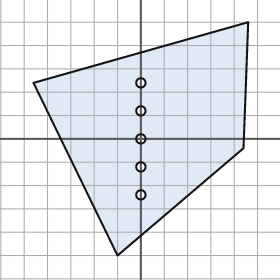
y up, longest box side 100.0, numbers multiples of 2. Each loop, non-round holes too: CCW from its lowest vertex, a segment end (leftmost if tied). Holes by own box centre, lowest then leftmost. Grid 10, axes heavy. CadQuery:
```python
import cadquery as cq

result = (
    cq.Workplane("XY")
    .moveTo(-10.0, -50.0)
    .lineTo(44.0, -4.0)
    .lineTo(46.0, 50.0)
    .lineTo(-46.0, 24.0)
    .close()
    .moveTo(0.0, -24.0)
    .circle(2.0)
    .moveTo(0.0, -12.0)
    .circle(2.0)
    .moveTo(0.0, 0.0)
    .circle(2.0)
    .moveTo(0.0, 12.0)
    .circle(2.0)
    .moveTo(0.0, 24.0)
    .circle(2.0)
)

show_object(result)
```